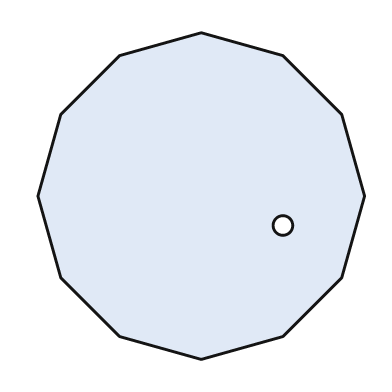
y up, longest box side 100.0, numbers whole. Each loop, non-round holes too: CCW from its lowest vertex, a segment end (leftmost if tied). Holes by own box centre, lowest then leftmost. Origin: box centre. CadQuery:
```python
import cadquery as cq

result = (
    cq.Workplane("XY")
    .moveTo(0.0, -50.0)
    .lineTo(25.0, -43.0)
    .lineTo(43.0, -25.0)
    .lineTo(50.0, 0.0)
    .lineTo(43.0, 25.0)
    .lineTo(25.0, 43.0)
    .lineTo(0.0, 50.0)
    .lineTo(-25.0, 43.0)
    .lineTo(-43.0, 25.0)
    .lineTo(-50.0, 0.0)
    .lineTo(-43.0, -25.0)
    .lineTo(-25.0, -43.0)
    .close()
    .moveTo(25.0, -9.0)
    .circle(3.0)
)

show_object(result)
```